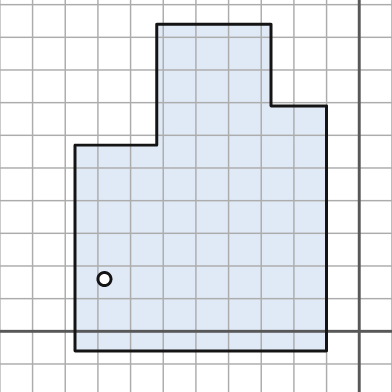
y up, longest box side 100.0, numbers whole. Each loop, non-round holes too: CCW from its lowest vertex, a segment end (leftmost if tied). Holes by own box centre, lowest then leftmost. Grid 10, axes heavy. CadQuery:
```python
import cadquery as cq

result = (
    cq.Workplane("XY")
    .moveTo(-87.0, -6.0)
    .lineTo(-10.0, -6.0)
    .lineTo(-10.0, 69.0)
    .lineTo(-27.0, 69.0)
    .lineTo(-27.0, 94.0)
    .lineTo(-62.0, 94.0)
    .lineTo(-62.0, 57.0)
    .lineTo(-87.0, 57.0)
    .close()
    .moveTo(-78.0, 16.0)
    .circle(2.0)
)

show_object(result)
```